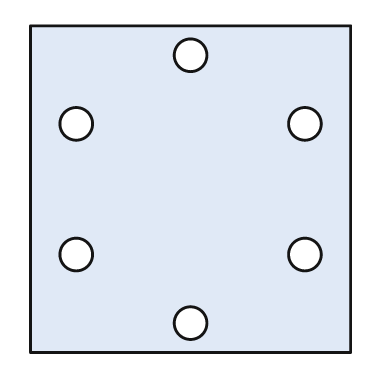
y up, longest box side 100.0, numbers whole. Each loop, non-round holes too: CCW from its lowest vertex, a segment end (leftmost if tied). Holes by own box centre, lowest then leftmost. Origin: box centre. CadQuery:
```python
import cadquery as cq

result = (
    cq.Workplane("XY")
    .moveTo(-49.0, -50.0)
    .lineTo(49.0, -50.0)
    .lineTo(49.0, 50.0)
    .lineTo(-49.0, 50.0)
    .close()
    .moveTo(0.0, -41.0)
    .circle(5.0)
    .moveTo(-35.0, -20.0)
    .circle(5.0)
    .moveTo(35.0, -20.0)
    .circle(5.0)
    .moveTo(-35.0, 20.0)
    .circle(5.0)
    .moveTo(35.0, 20.0)
    .circle(5.0)
    .moveTo(0.0, 41.0)
    .circle(5.0)
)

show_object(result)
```